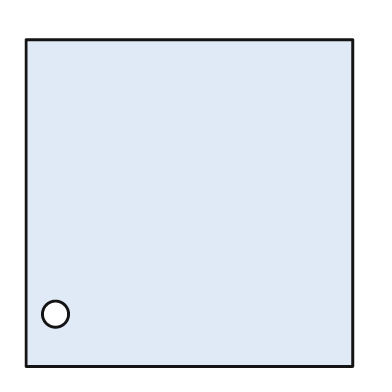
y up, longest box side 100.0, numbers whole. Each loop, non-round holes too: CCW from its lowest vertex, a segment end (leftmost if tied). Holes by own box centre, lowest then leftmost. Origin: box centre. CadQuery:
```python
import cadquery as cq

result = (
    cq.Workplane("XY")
    .moveTo(-50.0, -50.0)
    .lineTo(50.0, -50.0)
    .lineTo(50.0, 50.0)
    .lineTo(-50.0, 50.0)
    .close()
    .moveTo(-41.0, -34.0)
    .circle(4.0)
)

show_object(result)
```